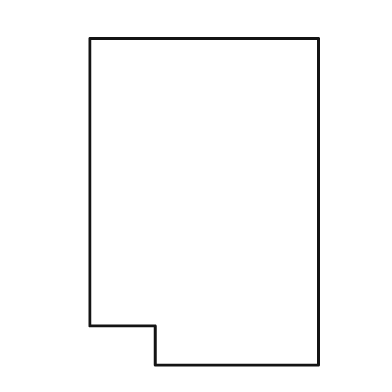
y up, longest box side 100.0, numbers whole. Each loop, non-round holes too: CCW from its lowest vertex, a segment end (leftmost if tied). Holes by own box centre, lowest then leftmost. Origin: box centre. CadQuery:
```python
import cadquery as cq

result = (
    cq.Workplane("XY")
    .moveTo(-15.0, -50.0)
    .lineTo(35.0, -50.0)
    .lineTo(35.0, 50.0)
    .lineTo(-35.0, 50.0)
    .lineTo(-35.0, -38.0)
    .lineTo(-15.0, -38.0)
    .close()
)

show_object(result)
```